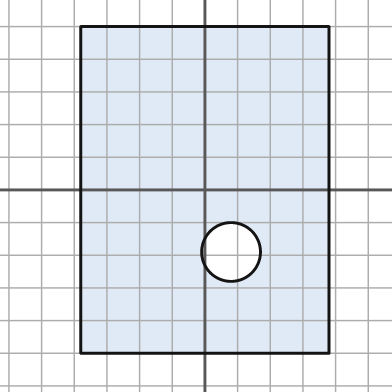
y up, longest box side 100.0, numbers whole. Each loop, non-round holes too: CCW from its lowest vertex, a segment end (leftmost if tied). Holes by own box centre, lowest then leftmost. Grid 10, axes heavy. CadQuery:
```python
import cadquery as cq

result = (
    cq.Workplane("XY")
    .moveTo(-38.0, -50.0)
    .lineTo(38.0, -50.0)
    .lineTo(38.0, 50.0)
    .lineTo(-38.0, 50.0)
    .close()
    .moveTo(8.0, -19.0)
    .circle(9.0)
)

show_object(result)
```